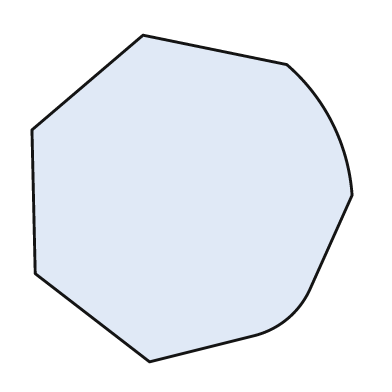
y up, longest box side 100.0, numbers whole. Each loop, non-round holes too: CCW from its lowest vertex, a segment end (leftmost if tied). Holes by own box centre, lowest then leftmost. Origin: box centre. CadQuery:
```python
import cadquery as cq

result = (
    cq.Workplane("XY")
    .moveTo(-13.0, -50.0)
    .lineTo(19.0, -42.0)
    .threePointArc((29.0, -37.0), (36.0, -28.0))
    .lineTo(49.0, 1.0)
    .threePointArc((43.0, 23.0), (29.0, 41.0))
    .lineTo(-15.0, 50.0)
    .lineTo(-49.0, 21.0)
    .lineTo(-48.0, -23.0)
    .close()
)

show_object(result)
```